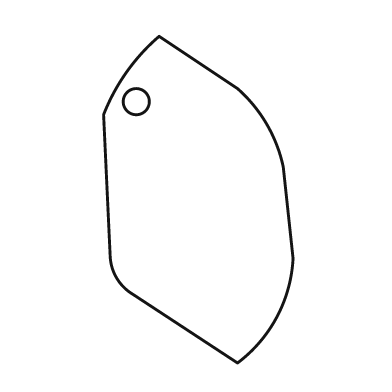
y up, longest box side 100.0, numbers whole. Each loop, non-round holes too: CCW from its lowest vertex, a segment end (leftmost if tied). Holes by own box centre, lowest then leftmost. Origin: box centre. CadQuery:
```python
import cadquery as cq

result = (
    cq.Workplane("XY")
    .moveTo(12.0, -50.0)
    .threePointArc((24.0, -36.0), (29.0, -18.0))
    .lineTo(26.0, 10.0)
    .threePointArc((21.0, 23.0), (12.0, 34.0))
    .lineTo(-12.0, 50.0)
    .threePointArc((-22.0, 39.0), (-29.0, 26.0))
    .lineTo(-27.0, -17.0)
    .threePointArc((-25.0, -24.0), (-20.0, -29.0))
    .close()
    .moveTo(-19.0, 30.0)
    .circle(4.0)
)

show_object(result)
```